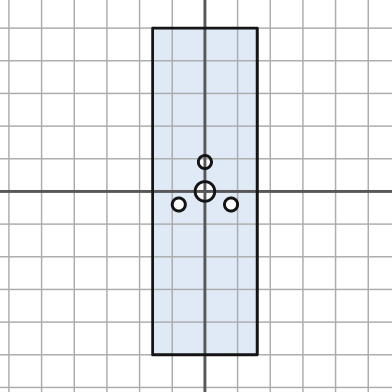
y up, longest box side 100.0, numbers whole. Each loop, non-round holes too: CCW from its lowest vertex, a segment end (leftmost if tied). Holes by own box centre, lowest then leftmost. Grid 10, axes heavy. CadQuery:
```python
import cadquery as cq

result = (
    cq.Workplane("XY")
    .moveTo(-16.0, -50.0)
    .lineTo(16.0, -50.0)
    .lineTo(16.0, 50.0)
    .lineTo(-16.0, 50.0)
    .close()
    .moveTo(-8.0, -4.0)
    .circle(2.0)
    .moveTo(8.0, -4.0)
    .circle(2.0)
    .moveTo(0.0, 0.0)
    .circle(3.0)
    .moveTo(0.0, 9.0)
    .circle(2.0)
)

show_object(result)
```